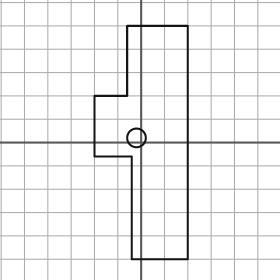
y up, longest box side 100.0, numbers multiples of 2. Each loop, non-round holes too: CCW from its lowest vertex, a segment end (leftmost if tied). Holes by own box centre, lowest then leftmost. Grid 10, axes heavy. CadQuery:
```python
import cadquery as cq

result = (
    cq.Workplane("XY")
    .moveTo(-4.0, -50.0)
    .lineTo(20.0, -50.0)
    .lineTo(20.0, 50.0)
    .lineTo(-6.0, 50.0)
    .lineTo(-6.0, 20.0)
    .lineTo(-20.0, 20.0)
    .lineTo(-20.0, -6.0)
    .lineTo(-4.0, -6.0)
    .close()
    .moveTo(-2.0, 2.0)
    .circle(4.0)
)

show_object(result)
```